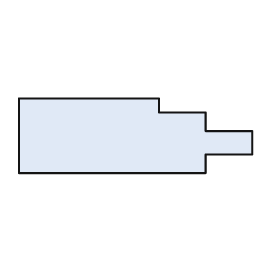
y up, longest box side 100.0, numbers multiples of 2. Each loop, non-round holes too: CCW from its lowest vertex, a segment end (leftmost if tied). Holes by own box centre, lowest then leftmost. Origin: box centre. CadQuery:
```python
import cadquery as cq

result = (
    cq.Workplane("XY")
    .moveTo(-50.0, -16.0)
    .lineTo(30.0, -16.0)
    .lineTo(30.0, -8.0)
    .lineTo(50.0, -8.0)
    .lineTo(50.0, 2.0)
    .lineTo(30.0, 2.0)
    .lineTo(30.0, 10.0)
    .lineTo(10.0, 10.0)
    .lineTo(10.0, 16.0)
    .lineTo(-50.0, 16.0)
    .close()
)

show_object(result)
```